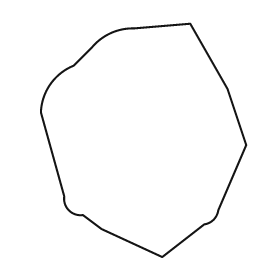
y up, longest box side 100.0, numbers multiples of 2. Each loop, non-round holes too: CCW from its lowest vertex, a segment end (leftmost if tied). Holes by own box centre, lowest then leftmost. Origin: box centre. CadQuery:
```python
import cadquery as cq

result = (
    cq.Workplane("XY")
    .moveTo(8.0, -50.0)
    .lineTo(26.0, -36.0)
    .threePointArc((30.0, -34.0), (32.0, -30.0))
    .lineTo(44.0, -2.0)
    .lineTo(36.0, 22.0)
    .lineTo(20.0, 50.0)
    .lineTo(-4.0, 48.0)
    .threePointArc((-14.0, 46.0), (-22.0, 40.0))
    .lineTo(-30.0, 32.0)
    .threePointArc((-40.0, 24.0), (-44.0, 12.0))
    .lineTo(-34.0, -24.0)
    .threePointArc((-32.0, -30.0), (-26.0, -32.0))
    .lineTo(-18.0, -38.0)
    .close()
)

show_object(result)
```